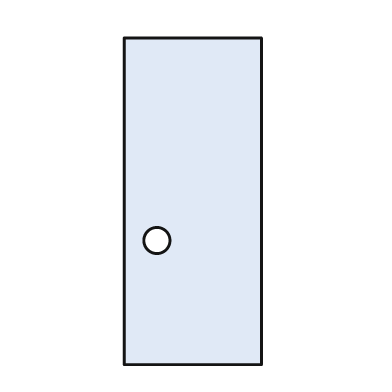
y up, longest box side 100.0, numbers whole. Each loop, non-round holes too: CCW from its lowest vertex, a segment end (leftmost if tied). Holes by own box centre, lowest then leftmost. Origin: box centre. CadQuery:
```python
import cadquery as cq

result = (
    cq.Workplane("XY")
    .moveTo(-21.0, -50.0)
    .lineTo(21.0, -50.0)
    .lineTo(21.0, 50.0)
    .lineTo(-21.0, 50.0)
    .close()
    .moveTo(-11.0, -12.0)
    .circle(4.0)
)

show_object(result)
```